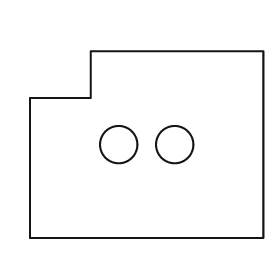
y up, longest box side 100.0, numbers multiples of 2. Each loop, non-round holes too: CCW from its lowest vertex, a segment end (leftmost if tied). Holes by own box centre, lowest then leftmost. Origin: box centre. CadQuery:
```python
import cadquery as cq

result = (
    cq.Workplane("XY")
    .moveTo(-50.0, -40.0)
    .lineTo(50.0, -40.0)
    .lineTo(50.0, 40.0)
    .lineTo(-24.0, 40.0)
    .lineTo(-24.0, 20.0)
    .lineTo(-50.0, 20.0)
    .close()
    .moveTo(-12.0, 0.0)
    .circle(8.0)
    .moveTo(12.0, 0.0)
    .circle(8.0)
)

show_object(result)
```